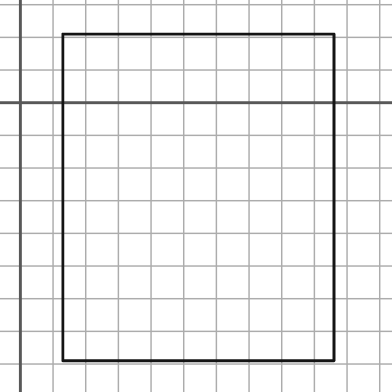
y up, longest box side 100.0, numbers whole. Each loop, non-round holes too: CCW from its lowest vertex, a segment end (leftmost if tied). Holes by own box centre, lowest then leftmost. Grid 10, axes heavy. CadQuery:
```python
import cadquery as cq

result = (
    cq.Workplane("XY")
    .moveTo(13.0, -79.0)
    .lineTo(96.0, -79.0)
    .lineTo(96.0, 21.0)
    .lineTo(13.0, 21.0)
    .close()
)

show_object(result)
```